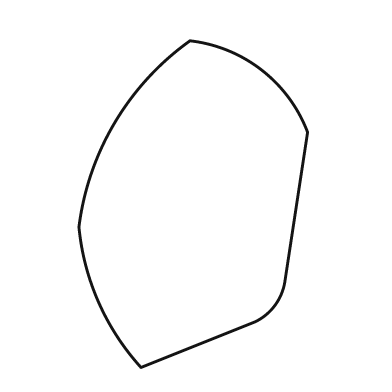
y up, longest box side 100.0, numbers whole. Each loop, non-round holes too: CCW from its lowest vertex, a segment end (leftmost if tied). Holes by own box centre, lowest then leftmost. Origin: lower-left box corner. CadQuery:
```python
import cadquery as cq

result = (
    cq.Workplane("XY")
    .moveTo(19.0, 0.0)
    .lineTo(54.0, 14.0)
    .threePointArc((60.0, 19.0), (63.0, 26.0))
    .lineTo(70.0, 72.0)
    .threePointArc((56.0, 91.0), (34.0, 100.0))
    .threePointArc((11.0, 75.0), (0.0, 43.0))
    .threePointArc((6.0, 20.0), (19.0, 0.0))
    .close()
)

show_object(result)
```